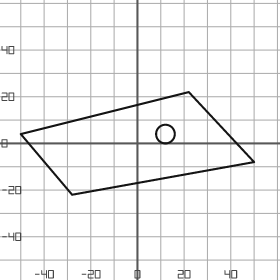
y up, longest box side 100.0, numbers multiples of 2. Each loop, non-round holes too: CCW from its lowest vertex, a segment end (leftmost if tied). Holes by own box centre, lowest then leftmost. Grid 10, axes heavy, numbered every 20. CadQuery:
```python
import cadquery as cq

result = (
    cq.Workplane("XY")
    .moveTo(-28.0, -22.0)
    .lineTo(50.0, -8.0)
    .lineTo(22.0, 22.0)
    .lineTo(-50.0, 4.0)
    .close()
    .moveTo(12.0, 4.0)
    .circle(4.0)
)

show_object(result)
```